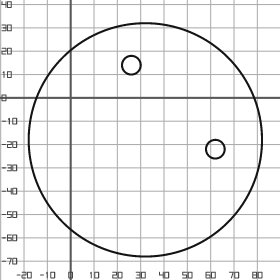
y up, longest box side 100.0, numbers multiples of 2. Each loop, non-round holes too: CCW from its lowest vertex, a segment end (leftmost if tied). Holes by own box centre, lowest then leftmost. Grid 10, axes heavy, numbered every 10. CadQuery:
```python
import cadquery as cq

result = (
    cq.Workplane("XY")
    .moveTo(32.0, -18.0)
    .circle(50.0)
    .moveTo(62.0, -22.0)
    .circle(4.0)
    .moveTo(26.0, 14.0)
    .circle(4.0)
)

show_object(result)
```